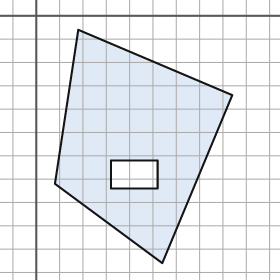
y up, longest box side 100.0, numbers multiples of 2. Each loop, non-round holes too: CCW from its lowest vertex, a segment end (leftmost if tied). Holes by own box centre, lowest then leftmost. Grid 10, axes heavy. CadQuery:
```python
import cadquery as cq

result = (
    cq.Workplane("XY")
    .moveTo(54.0, -106.0)
    .lineTo(84.0, -34.0)
    .lineTo(18.0, -6.0)
    .lineTo(8.0, -72.0)
    .close()
    .moveTo(32.0, -74.0)
    .lineTo(52.0, -74.0)
    .lineTo(52.0, -62.0)
    .lineTo(32.0, -62.0)
    .close()
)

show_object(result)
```